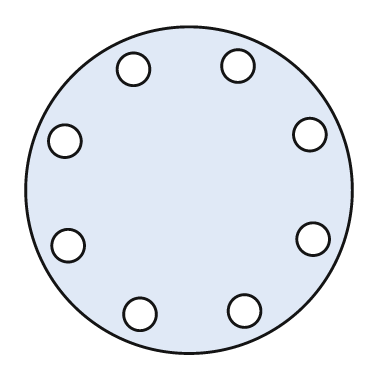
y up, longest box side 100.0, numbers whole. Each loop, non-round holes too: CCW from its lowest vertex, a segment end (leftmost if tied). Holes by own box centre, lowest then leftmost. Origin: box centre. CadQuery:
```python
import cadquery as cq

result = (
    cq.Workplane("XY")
    .moveTo(0.0, 0.0)
    .circle(50.0)
    .moveTo(-15.0, -38.0)
    .circle(5.0)
    .moveTo(17.0, -37.0)
    .circle(5.0)
    .moveTo(-37.0, -17.0)
    .circle(5.0)
    .moveTo(38.0, -15.0)
    .circle(5.0)
    .moveTo(-38.0, 15.0)
    .circle(5.0)
    .moveTo(37.0, 17.0)
    .circle(5.0)
    .moveTo(-17.0, 37.0)
    .circle(5.0)
    .moveTo(15.0, 38.0)
    .circle(5.0)
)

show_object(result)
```